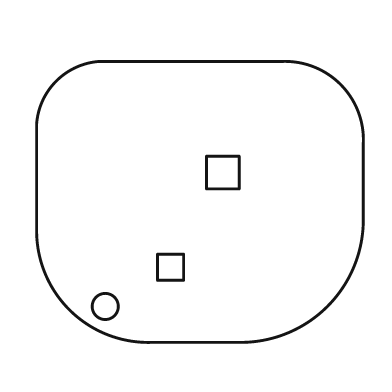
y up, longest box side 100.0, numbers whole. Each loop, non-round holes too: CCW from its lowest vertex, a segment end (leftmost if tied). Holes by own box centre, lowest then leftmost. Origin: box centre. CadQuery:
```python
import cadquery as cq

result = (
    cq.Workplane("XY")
    .moveTo(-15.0, -43.0)
    .lineTo(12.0, -43.0)
    .threePointArc((39.0, -32.0), (50.0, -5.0))
    .lineTo(50.0, 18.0)
    .threePointArc((43.0, 36.0), (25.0, 43.0))
    .lineTo(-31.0, 43.0)
    .threePointArc((-44.0, 37.0), (-50.0, 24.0))
    .lineTo(-50.0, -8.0)
    .threePointArc((-40.0, -33.0), (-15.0, -43.0))
    .close()
    .moveTo(-29.0, -32.0)
    .circle(4.0)
    .moveTo(-13.0, -24.0)
    .lineTo(-5.0, -24.0)
    .lineTo(-5.0, -16.0)
    .lineTo(-13.0, -16.0)
    .close()
    .moveTo(2.0, 4.0)
    .lineTo(12.0, 4.0)
    .lineTo(12.0, 14.0)
    .lineTo(2.0, 14.0)
    .close()
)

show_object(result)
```